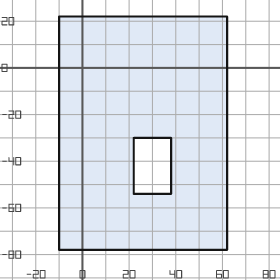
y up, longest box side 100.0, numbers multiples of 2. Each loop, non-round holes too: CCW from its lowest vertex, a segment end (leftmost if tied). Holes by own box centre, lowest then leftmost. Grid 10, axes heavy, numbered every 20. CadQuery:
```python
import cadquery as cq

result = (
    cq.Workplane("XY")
    .moveTo(-10.0, -78.0)
    .lineTo(62.0, -78.0)
    .lineTo(62.0, 22.0)
    .lineTo(-10.0, 22.0)
    .close()
    .moveTo(22.0, -54.0)
    .lineTo(38.0, -54.0)
    .lineTo(38.0, -30.0)
    .lineTo(22.0, -30.0)
    .close()
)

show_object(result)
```